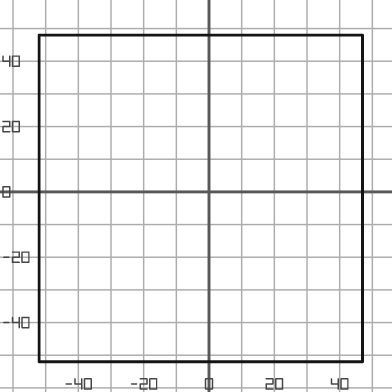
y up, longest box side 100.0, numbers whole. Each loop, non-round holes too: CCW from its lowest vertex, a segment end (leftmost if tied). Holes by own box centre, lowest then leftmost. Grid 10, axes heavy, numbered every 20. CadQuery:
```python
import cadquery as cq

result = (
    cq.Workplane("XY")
    .moveTo(-52.0, -52.0)
    .lineTo(47.0, -52.0)
    .lineTo(47.0, 48.0)
    .lineTo(-52.0, 48.0)
    .close()
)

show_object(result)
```